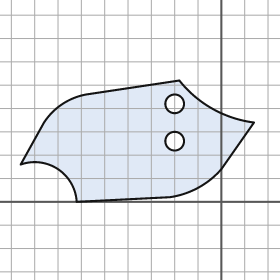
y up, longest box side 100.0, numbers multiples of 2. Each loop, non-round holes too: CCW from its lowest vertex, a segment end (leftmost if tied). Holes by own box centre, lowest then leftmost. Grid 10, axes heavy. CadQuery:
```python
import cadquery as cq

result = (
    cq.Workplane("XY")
    .moveTo(-62.0, 0.0)
    .lineTo(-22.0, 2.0)
    .threePointArc((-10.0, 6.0), (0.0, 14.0))
    .lineTo(14.0, 34.0)
    .threePointArc((-4.0, 40.0), (-18.0, 52.0))
    .lineTo(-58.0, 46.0)
    .threePointArc((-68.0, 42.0), (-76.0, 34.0))
    .lineTo(-86.0, 16.0)
    .threePointArc((-70.0, 14.0), (-62.0, 0.0))
    .close()
    .moveTo(-20.0, 26.0)
    .circle(4.0)
    .moveTo(-20.0, 42.0)
    .circle(4.0)
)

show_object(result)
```